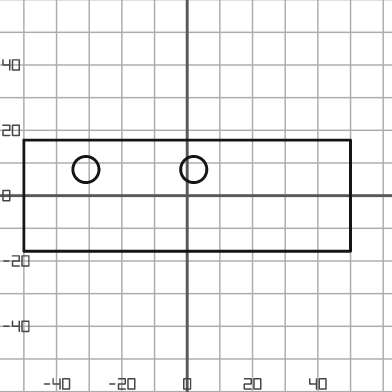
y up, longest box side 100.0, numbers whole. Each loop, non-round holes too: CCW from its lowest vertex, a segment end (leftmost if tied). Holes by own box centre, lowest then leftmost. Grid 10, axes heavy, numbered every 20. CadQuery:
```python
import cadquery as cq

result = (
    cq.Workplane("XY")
    .moveTo(-50.0, -17.0)
    .lineTo(50.0, -17.0)
    .lineTo(50.0, 17.0)
    .lineTo(-50.0, 17.0)
    .close()
    .moveTo(-31.0, 8.0)
    .circle(4.0)
    .moveTo(2.0, 8.0)
    .circle(4.0)
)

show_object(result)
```